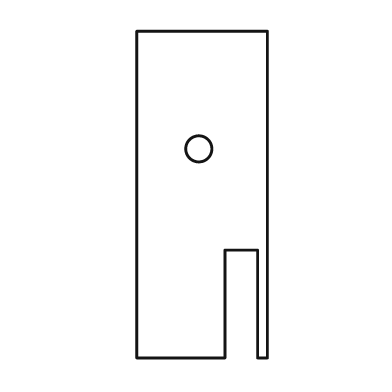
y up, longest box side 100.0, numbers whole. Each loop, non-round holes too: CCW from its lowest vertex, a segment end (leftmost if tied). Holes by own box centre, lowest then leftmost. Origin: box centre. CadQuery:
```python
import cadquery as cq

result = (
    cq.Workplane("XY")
    .moveTo(-20.0, -50.0)
    .lineTo(7.0, -50.0)
    .lineTo(7.0, -17.0)
    .lineTo(17.0, -17.0)
    .lineTo(17.0, -50.0)
    .lineTo(20.0, -50.0)
    .lineTo(20.0, 50.0)
    .lineTo(-20.0, 50.0)
    .close()
    .moveTo(-1.0, 14.0)
    .circle(4.0)
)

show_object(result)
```